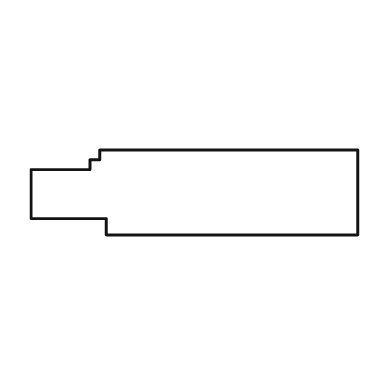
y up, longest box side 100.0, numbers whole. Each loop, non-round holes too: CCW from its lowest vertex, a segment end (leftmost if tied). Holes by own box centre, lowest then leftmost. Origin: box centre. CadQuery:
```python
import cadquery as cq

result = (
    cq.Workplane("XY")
    .moveTo(-27.0, -13.0)
    .lineTo(50.0, -13.0)
    .lineTo(50.0, 13.0)
    .lineTo(-29.0, 13.0)
    .lineTo(-29.0, 10.0)
    .lineTo(-32.0, 10.0)
    .lineTo(-32.0, 7.0)
    .lineTo(-50.0, 7.0)
    .lineTo(-50.0, -8.0)
    .lineTo(-27.0, -8.0)
    .close()
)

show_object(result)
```